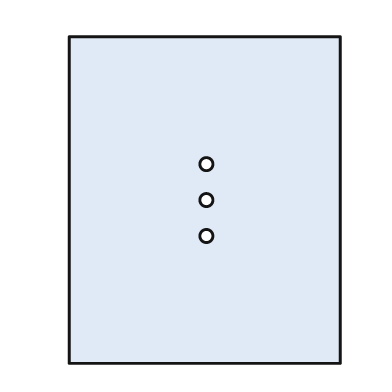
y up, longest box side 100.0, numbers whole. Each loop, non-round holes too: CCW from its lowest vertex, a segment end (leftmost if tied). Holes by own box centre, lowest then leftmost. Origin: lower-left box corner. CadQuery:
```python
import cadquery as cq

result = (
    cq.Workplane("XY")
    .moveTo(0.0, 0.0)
    .lineTo(83.0, 0.0)
    .lineTo(83.0, 100.0)
    .lineTo(0.0, 100.0)
    .close()
    .moveTo(42.0, 39.0)
    .circle(2.0)
    .moveTo(42.0, 50.0)
    .circle(2.0)
    .moveTo(42.0, 61.0)
    .circle(2.0)
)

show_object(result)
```